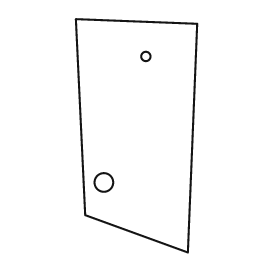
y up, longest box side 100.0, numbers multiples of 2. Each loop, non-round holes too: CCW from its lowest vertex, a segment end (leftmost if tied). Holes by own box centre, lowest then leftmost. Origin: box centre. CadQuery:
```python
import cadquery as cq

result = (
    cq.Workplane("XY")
    .moveTo(22.0, -50.0)
    .lineTo(26.0, 48.0)
    .lineTo(-26.0, 50.0)
    .lineTo(-22.0, -34.0)
    .close()
    .moveTo(-14.0, -20.0)
    .circle(4.0)
    .moveTo(4.0, 34.0)
    .circle(2.0)
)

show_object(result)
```